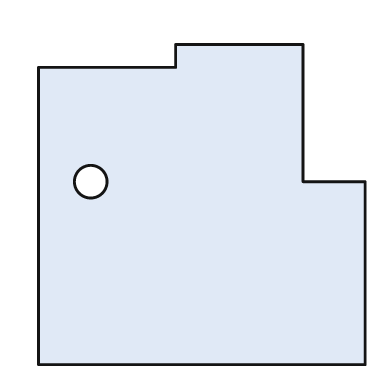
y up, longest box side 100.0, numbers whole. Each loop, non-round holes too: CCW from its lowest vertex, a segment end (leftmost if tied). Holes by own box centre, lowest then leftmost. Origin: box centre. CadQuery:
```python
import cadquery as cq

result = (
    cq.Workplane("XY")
    .moveTo(-50.0, -49.0)
    .lineTo(50.0, -49.0)
    .lineTo(50.0, 7.0)
    .lineTo(31.0, 7.0)
    .lineTo(31.0, 49.0)
    .lineTo(-8.0, 49.0)
    .lineTo(-8.0, 42.0)
    .lineTo(-50.0, 42.0)
    .close()
    .moveTo(-34.0, 7.0)
    .circle(5.0)
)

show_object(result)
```